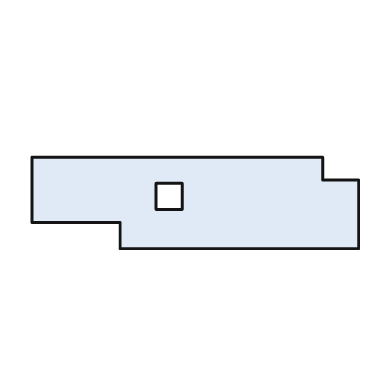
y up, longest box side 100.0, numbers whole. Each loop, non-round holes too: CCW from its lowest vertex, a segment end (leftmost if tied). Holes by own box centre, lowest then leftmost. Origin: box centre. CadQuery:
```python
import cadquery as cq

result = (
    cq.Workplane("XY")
    .moveTo(-23.0, -14.0)
    .lineTo(50.0, -14.0)
    .lineTo(50.0, 7.0)
    .lineTo(39.0, 7.0)
    .lineTo(39.0, 14.0)
    .lineTo(-50.0, 14.0)
    .lineTo(-50.0, -6.0)
    .lineTo(-23.0, -6.0)
    .close()
    .moveTo(-12.0, -2.0)
    .lineTo(-4.0, -2.0)
    .lineTo(-4.0, 6.0)
    .lineTo(-12.0, 6.0)
    .close()
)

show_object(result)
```